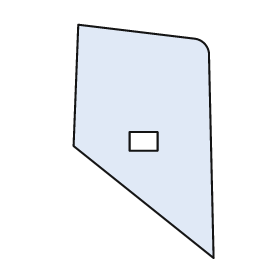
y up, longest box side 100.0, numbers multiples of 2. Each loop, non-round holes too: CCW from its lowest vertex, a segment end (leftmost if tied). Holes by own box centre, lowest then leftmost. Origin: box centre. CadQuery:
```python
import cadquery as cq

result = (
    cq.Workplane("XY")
    .moveTo(30.0, -50.0)
    .lineTo(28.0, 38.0)
    .threePointArc((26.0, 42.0), (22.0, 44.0))
    .lineTo(-28.0, 50.0)
    .lineTo(-30.0, -2.0)
    .close()
    .moveTo(-6.0, -4.0)
    .lineTo(6.0, -4.0)
    .lineTo(6.0, 4.0)
    .lineTo(-6.0, 4.0)
    .close()
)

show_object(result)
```